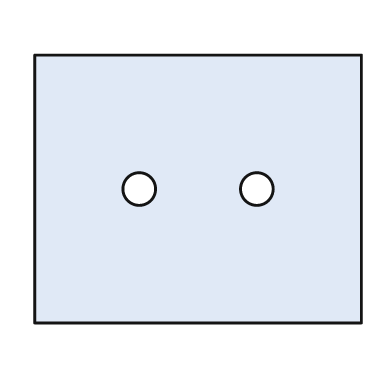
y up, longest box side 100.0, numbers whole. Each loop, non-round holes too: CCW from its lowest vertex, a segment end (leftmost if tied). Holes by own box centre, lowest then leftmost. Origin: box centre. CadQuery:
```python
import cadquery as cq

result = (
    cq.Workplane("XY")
    .moveTo(-50.0, -41.0)
    .lineTo(50.0, -41.0)
    .lineTo(50.0, 41.0)
    .lineTo(-50.0, 41.0)
    .close()
    .moveTo(-18.0, 0.0)
    .circle(5.0)
    .moveTo(18.0, 0.0)
    .circle(5.0)
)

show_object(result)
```